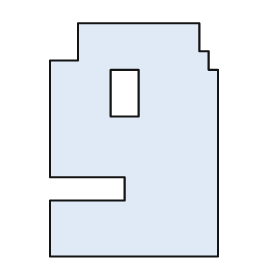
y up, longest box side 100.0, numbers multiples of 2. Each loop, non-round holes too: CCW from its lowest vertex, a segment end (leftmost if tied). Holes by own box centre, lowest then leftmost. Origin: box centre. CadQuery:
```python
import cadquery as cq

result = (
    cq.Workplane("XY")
    .moveTo(-36.0, -50.0)
    .lineTo(36.0, -50.0)
    .lineTo(36.0, 30.0)
    .lineTo(32.0, 30.0)
    .lineTo(32.0, 38.0)
    .lineTo(28.0, 38.0)
    .lineTo(28.0, 50.0)
    .lineTo(-24.0, 50.0)
    .lineTo(-24.0, 34.0)
    .lineTo(-36.0, 34.0)
    .lineTo(-36.0, -16.0)
    .lineTo(-4.0, -16.0)
    .lineTo(-4.0, -26.0)
    .lineTo(-36.0, -26.0)
    .close()
    .moveTo(-10.0, 10.0)
    .lineTo(2.0, 10.0)
    .lineTo(2.0, 30.0)
    .lineTo(-10.0, 30.0)
    .close()
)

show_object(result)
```